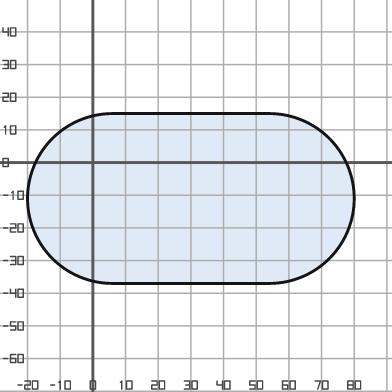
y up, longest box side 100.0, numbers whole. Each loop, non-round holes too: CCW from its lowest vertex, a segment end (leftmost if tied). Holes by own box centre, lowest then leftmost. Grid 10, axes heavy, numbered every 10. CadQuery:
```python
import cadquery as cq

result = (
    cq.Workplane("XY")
    .moveTo(6.0, -37.0)
    .lineTo(54.0, -37.0)
    .threePointArc((80.0, -11.0), (54.0, 15.0))
    .lineTo(6.0, 15.0)
    .threePointArc((-20.0, -11.0), (6.0, -37.0))
    .close()
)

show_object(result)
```